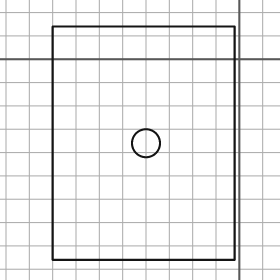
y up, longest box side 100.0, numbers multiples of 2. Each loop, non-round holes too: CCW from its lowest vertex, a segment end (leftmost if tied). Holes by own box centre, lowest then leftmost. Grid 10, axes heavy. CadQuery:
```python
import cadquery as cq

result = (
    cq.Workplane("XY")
    .moveTo(-80.0, -86.0)
    .lineTo(-2.0, -86.0)
    .lineTo(-2.0, 14.0)
    .lineTo(-80.0, 14.0)
    .close()
    .moveTo(-40.0, -36.0)
    .circle(6.0)
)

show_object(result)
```